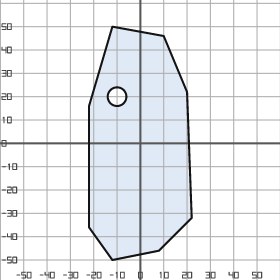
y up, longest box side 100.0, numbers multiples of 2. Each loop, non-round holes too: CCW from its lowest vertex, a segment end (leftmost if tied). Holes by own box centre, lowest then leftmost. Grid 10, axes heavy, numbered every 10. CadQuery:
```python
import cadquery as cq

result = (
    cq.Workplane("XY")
    .moveTo(-12.0, -50.0)
    .lineTo(8.0, -46.0)
    .lineTo(22.0, -32.0)
    .lineTo(20.0, 22.0)
    .lineTo(10.0, 46.0)
    .lineTo(-12.0, 50.0)
    .lineTo(-22.0, 16.0)
    .lineTo(-22.0, -36.0)
    .close()
    .moveTo(-10.0, 20.0)
    .circle(4.0)
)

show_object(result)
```